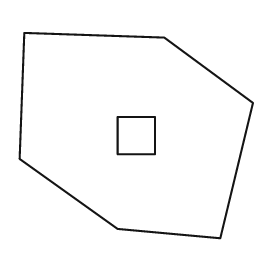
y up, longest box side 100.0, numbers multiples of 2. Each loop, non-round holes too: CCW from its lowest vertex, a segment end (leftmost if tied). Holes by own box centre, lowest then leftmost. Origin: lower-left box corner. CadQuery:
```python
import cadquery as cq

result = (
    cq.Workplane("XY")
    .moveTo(86.0, 0.0)
    .lineTo(100.0, 58.0)
    .lineTo(62.0, 86.0)
    .lineTo(2.0, 88.0)
    .lineTo(0.0, 34.0)
    .lineTo(42.0, 4.0)
    .close()
    .moveTo(42.0, 36.0)
    .lineTo(58.0, 36.0)
    .lineTo(58.0, 52.0)
    .lineTo(42.0, 52.0)
    .close()
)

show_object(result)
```